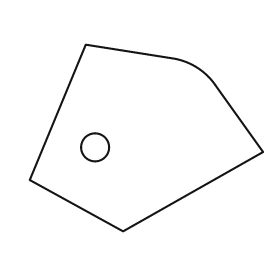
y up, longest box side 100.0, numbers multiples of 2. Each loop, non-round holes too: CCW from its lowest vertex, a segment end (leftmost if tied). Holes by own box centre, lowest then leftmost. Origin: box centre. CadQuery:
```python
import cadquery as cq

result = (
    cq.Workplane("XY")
    .moveTo(-10.0, -40.0)
    .lineTo(50.0, -6.0)
    .lineTo(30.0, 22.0)
    .threePointArc((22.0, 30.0), (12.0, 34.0))
    .lineTo(-26.0, 40.0)
    .lineTo(-50.0, -18.0)
    .close()
    .moveTo(-22.0, -4.0)
    .circle(6.0)
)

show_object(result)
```